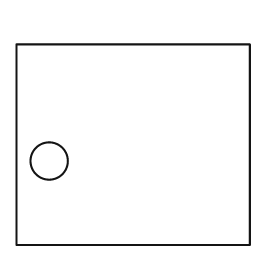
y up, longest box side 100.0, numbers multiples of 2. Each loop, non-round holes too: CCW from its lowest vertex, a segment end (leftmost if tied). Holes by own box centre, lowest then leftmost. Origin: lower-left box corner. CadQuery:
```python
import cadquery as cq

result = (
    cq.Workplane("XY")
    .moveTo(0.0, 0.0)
    .lineTo(100.0, 0.0)
    .lineTo(100.0, 86.0)
    .lineTo(0.0, 86.0)
    .close()
    .moveTo(14.0, 36.0)
    .circle(8.0)
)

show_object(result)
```